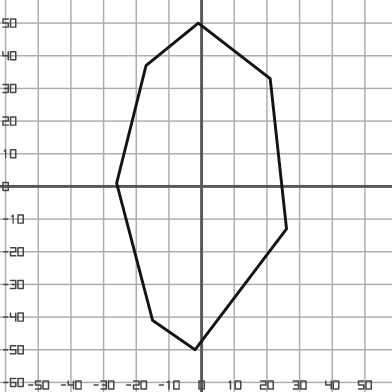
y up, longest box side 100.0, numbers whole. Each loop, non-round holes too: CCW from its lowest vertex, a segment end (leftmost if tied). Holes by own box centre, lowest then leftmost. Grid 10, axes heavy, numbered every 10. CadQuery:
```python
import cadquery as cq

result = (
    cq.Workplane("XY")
    .moveTo(-2.0, -50.0)
    .lineTo(26.0, -13.0)
    .lineTo(21.0, 33.0)
    .lineTo(-1.0, 50.0)
    .lineTo(-17.0, 37.0)
    .lineTo(-26.0, 1.0)
    .lineTo(-15.0, -41.0)
    .close()
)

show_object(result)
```